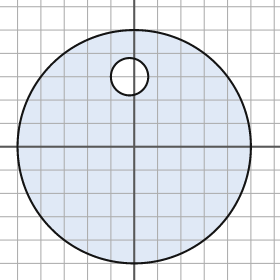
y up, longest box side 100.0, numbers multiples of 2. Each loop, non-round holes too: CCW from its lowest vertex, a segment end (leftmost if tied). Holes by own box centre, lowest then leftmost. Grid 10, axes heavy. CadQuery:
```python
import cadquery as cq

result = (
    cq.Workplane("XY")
    .moveTo(0.0, 0.0)
    .circle(50.0)
    .moveTo(-2.0, 30.0)
    .circle(8.0)
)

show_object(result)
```